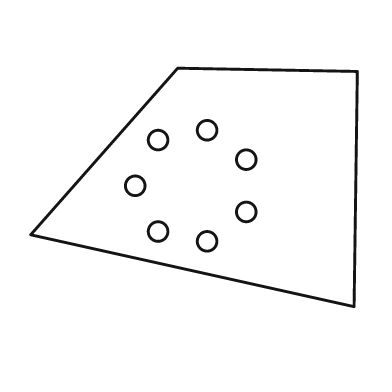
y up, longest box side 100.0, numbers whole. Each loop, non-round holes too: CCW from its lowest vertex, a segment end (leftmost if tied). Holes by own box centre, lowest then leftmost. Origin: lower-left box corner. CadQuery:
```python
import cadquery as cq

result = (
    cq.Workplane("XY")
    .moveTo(99.0, 0.0)
    .lineTo(100.0, 72.0)
    .lineTo(45.0, 73.0)
    .lineTo(0.0, 22.0)
    .close()
    .moveTo(54.0, 20.0)
    .circle(3.0)
    .moveTo(39.0, 23.0)
    .circle(3.0)
    .moveTo(66.0, 29.0)
    .circle(3.0)
    .moveTo(32.0, 37.0)
    .circle(3.0)
    .moveTo(66.0, 45.0)
    .circle(3.0)
    .moveTo(39.0, 51.0)
    .circle(3.0)
    .moveTo(54.0, 54.0)
    .circle(3.0)
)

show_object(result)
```